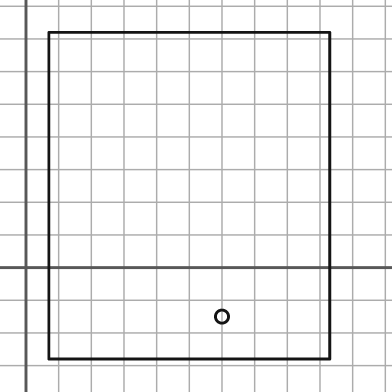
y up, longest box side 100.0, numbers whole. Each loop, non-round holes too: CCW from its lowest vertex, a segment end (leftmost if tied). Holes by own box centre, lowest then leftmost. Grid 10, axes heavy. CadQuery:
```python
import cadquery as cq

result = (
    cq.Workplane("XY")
    .moveTo(7.0, -28.0)
    .lineTo(93.0, -28.0)
    .lineTo(93.0, 72.0)
    .lineTo(7.0, 72.0)
    .close()
    .moveTo(60.0, -15.0)
    .circle(2.0)
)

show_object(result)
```